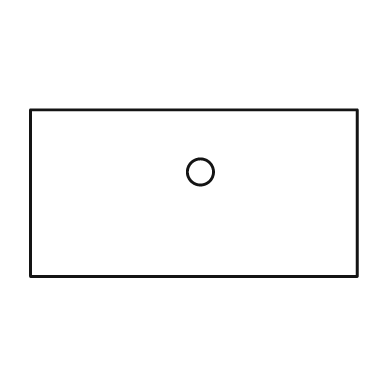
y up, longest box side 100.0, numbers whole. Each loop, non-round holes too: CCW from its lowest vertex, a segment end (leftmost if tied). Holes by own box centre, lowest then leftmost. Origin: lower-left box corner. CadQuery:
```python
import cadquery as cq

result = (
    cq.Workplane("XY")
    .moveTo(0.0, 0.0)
    .lineTo(100.0, 0.0)
    .lineTo(100.0, 51.0)
    .lineTo(0.0, 51.0)
    .close()
    .moveTo(52.0, 32.0)
    .circle(4.0)
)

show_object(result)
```